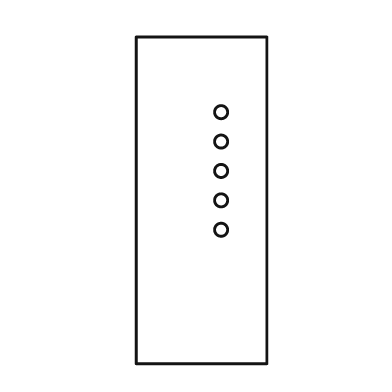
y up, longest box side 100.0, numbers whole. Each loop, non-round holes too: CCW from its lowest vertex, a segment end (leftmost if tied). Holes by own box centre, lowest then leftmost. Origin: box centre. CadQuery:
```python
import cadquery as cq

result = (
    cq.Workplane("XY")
    .moveTo(-20.0, -50.0)
    .lineTo(20.0, -50.0)
    .lineTo(20.0, 50.0)
    .lineTo(-20.0, 50.0)
    .close()
    .moveTo(6.0, -9.0)
    .circle(2.0)
    .moveTo(6.0, 0.0)
    .circle(2.0)
    .moveTo(6.0, 9.0)
    .circle(2.0)
    .moveTo(6.0, 18.0)
    .circle(2.0)
    .moveTo(6.0, 27.0)
    .circle(2.0)
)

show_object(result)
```